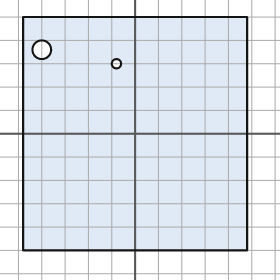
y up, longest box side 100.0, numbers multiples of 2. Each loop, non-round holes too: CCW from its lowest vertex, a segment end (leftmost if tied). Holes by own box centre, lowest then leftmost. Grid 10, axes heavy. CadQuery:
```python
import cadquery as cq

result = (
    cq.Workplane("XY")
    .moveTo(-48.0, -50.0)
    .lineTo(48.0, -50.0)
    .lineTo(48.0, 50.0)
    .lineTo(-48.0, 50.0)
    .close()
    .moveTo(-8.0, 30.0)
    .circle(2.0)
    .moveTo(-40.0, 36.0)
    .circle(4.0)
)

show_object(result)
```